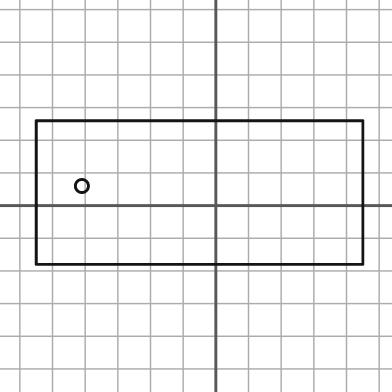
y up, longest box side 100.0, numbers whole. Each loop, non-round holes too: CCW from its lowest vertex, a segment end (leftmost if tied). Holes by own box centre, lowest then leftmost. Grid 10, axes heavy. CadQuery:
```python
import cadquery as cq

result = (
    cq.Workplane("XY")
    .moveTo(-55.0, -18.0)
    .lineTo(45.0, -18.0)
    .lineTo(45.0, 26.0)
    .lineTo(-55.0, 26.0)
    .close()
    .moveTo(-41.0, 6.0)
    .circle(2.0)
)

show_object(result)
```